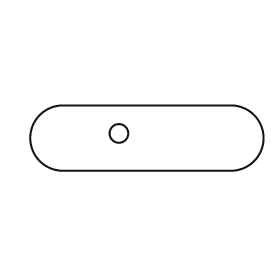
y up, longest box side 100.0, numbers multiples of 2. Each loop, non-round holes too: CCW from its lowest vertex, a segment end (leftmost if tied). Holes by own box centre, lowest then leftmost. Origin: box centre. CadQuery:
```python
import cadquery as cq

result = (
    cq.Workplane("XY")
    .moveTo(-36.0, -14.0)
    .lineTo(36.0, -14.0)
    .threePointArc((50.0, 0.0), (36.0, 14.0))
    .lineTo(-36.0, 14.0)
    .threePointArc((-50.0, 0.0), (-36.0, -14.0))
    .close()
    .moveTo(-12.0, 2.0)
    .circle(4.0)
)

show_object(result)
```